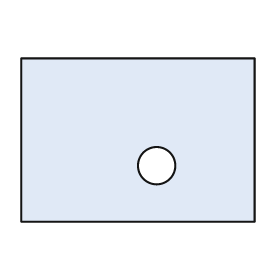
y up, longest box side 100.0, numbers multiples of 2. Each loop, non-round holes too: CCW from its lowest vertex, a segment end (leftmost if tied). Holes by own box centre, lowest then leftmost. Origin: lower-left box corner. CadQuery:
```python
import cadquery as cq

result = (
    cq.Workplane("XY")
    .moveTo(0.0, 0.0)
    .lineTo(100.0, 0.0)
    .lineTo(100.0, 70.0)
    .lineTo(0.0, 70.0)
    .close()
    .moveTo(58.0, 24.0)
    .circle(8.0)
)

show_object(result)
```